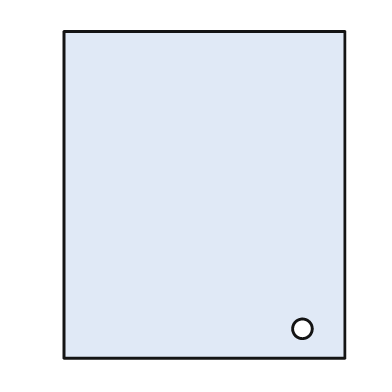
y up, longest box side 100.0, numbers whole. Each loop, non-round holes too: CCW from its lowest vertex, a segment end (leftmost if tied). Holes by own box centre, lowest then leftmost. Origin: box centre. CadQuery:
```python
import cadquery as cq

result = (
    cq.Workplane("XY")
    .moveTo(-43.0, -50.0)
    .lineTo(43.0, -50.0)
    .lineTo(43.0, 50.0)
    .lineTo(-43.0, 50.0)
    .close()
    .moveTo(30.0, -41.0)
    .circle(3.0)
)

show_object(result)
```